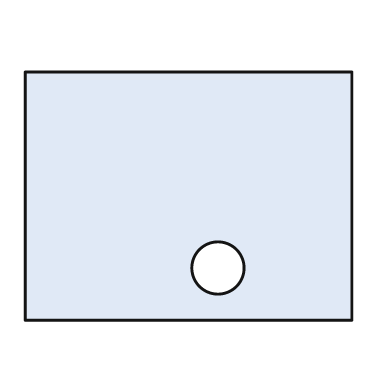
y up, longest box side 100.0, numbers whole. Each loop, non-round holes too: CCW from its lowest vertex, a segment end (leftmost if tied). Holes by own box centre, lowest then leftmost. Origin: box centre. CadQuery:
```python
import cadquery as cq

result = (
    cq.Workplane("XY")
    .moveTo(-50.0, -38.0)
    .lineTo(50.0, -38.0)
    .lineTo(50.0, 38.0)
    .lineTo(-50.0, 38.0)
    .close()
    .moveTo(9.0, -22.0)
    .circle(8.0)
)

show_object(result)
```